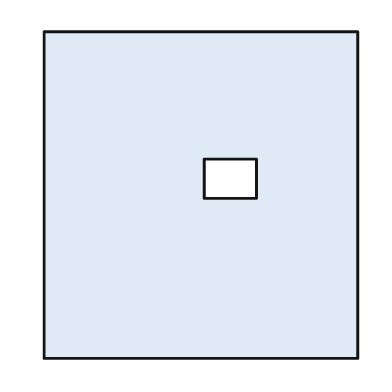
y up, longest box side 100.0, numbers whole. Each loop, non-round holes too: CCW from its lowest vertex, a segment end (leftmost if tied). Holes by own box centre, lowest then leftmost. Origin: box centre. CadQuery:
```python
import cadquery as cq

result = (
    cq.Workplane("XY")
    .moveTo(-48.0, -50.0)
    .lineTo(48.0, -50.0)
    .lineTo(48.0, 50.0)
    .lineTo(-48.0, 50.0)
    .close()
    .moveTo(1.0, -1.0)
    .lineTo(17.0, -1.0)
    .lineTo(17.0, 11.0)
    .lineTo(1.0, 11.0)
    .close()
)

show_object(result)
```